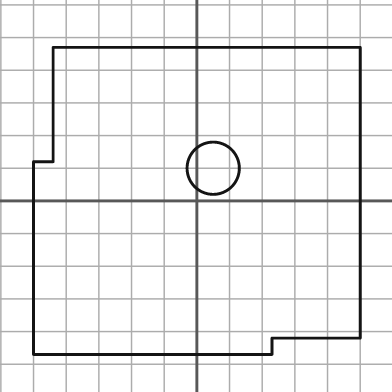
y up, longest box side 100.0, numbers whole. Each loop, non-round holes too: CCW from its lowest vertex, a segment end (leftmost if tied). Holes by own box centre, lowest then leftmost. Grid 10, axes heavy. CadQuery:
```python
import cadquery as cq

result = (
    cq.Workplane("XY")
    .moveTo(-50.0, -47.0)
    .lineTo(23.0, -47.0)
    .lineTo(23.0, -42.0)
    .lineTo(50.0, -42.0)
    .lineTo(50.0, 47.0)
    .lineTo(-44.0, 47.0)
    .lineTo(-44.0, 12.0)
    .lineTo(-50.0, 12.0)
    .close()
    .moveTo(5.0, 10.0)
    .circle(8.0)
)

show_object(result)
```